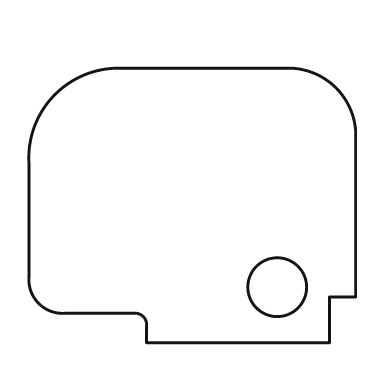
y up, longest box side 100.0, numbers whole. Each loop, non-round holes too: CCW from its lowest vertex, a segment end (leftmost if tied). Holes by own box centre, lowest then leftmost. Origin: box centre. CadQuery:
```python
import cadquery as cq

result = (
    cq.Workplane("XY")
    .moveTo(-14.0, -42.0)
    .lineTo(42.0, -42.0)
    .lineTo(42.0, -28.0)
    .lineTo(50.0, -28.0)
    .lineTo(50.0, 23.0)
    .threePointArc((44.0, 36.0), (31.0, 42.0))
    .lineTo(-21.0, 42.0)
    .threePointArc((-42.0, 34.0), (-50.0, 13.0))
    .lineTo(-50.0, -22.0)
    .threePointArc((-47.0, -30.0), (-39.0, -33.0))
    .lineTo(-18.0, -33.0)
    .threePointArc((-15.0, -34.0), (-14.0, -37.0))
    .close()
    .moveTo(26.0, -25.0)
    .circle(9.0)
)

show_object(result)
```